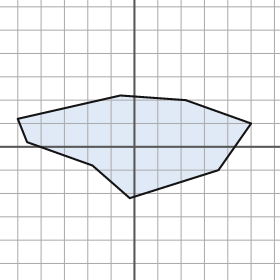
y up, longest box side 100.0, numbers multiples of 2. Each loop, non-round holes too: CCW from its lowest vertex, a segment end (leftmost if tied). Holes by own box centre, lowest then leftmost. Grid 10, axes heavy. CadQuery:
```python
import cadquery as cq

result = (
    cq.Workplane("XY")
    .moveTo(-2.0, -22.0)
    .lineTo(36.0, -10.0)
    .lineTo(50.0, 10.0)
    .lineTo(22.0, 20.0)
    .lineTo(-6.0, 22.0)
    .lineTo(-50.0, 12.0)
    .lineTo(-46.0, 2.0)
    .lineTo(-18.0, -8.0)
    .close()
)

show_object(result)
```